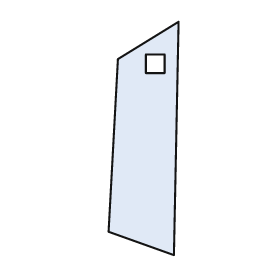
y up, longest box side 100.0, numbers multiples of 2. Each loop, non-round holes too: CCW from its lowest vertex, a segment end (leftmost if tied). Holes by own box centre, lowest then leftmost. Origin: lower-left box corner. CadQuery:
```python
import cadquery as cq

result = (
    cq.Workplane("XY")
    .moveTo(28.0, 0.0)
    .lineTo(30.0, 100.0)
    .lineTo(4.0, 84.0)
    .lineTo(0.0, 10.0)
    .close()
    .moveTo(16.0, 78.0)
    .lineTo(24.0, 78.0)
    .lineTo(24.0, 86.0)
    .lineTo(16.0, 86.0)
    .close()
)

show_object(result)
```